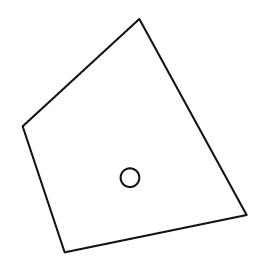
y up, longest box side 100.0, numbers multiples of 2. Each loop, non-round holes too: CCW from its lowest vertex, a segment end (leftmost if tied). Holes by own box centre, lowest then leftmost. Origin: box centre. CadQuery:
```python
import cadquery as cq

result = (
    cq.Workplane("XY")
    .moveTo(-30.0, -50.0)
    .lineTo(48.0, -34.0)
    .lineTo(2.0, 50.0)
    .lineTo(-48.0, 4.0)
    .close()
    .moveTo(-2.0, -18.0)
    .circle(4.0)
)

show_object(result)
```